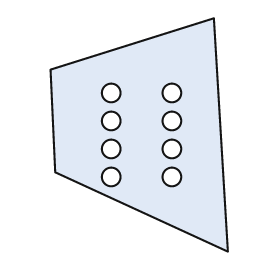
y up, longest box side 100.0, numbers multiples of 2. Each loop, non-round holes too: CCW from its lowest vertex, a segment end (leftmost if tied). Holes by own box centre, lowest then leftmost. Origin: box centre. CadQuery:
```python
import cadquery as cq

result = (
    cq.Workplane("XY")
    .moveTo(38.0, -50.0)
    .lineTo(32.0, 50.0)
    .lineTo(-38.0, 28.0)
    .lineTo(-36.0, -16.0)
    .close()
    .moveTo(-12.0, -18.0)
    .circle(4.0)
    .moveTo(14.0, -18.0)
    .circle(4.0)
    .moveTo(-12.0, -6.0)
    .circle(4.0)
    .moveTo(14.0, -6.0)
    .circle(4.0)
    .moveTo(-12.0, 6.0)
    .circle(4.0)
    .moveTo(14.0, 6.0)
    .circle(4.0)
    .moveTo(-12.0, 18.0)
    .circle(4.0)
    .moveTo(14.0, 18.0)
    .circle(4.0)
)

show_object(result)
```